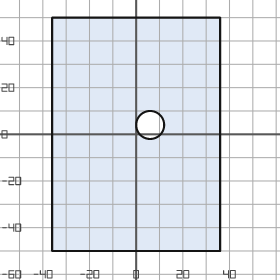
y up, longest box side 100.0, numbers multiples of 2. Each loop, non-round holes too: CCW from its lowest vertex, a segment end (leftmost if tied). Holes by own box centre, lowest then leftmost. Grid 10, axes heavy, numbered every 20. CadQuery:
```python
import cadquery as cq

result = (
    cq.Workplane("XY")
    .moveTo(-36.0, -50.0)
    .lineTo(36.0, -50.0)
    .lineTo(36.0, 50.0)
    .lineTo(-36.0, 50.0)
    .close()
    .moveTo(6.0, 4.0)
    .circle(6.0)
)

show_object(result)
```